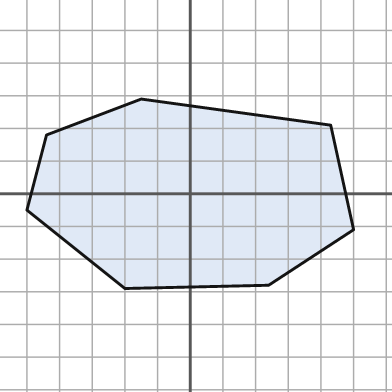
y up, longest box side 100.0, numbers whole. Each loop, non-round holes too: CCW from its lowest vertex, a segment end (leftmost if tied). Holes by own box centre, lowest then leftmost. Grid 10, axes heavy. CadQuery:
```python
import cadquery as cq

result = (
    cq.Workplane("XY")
    .moveTo(-20.0, -29.0)
    .lineTo(24.0, -28.0)
    .lineTo(50.0, -11.0)
    .lineTo(43.0, 21.0)
    .lineTo(-15.0, 29.0)
    .lineTo(-44.0, 18.0)
    .lineTo(-50.0, -5.0)
    .close()
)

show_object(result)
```